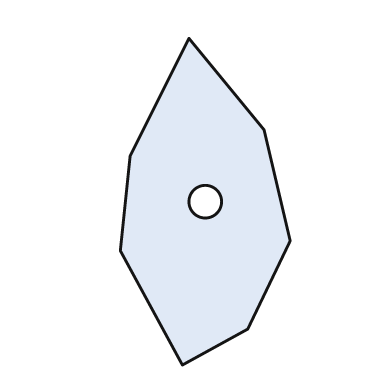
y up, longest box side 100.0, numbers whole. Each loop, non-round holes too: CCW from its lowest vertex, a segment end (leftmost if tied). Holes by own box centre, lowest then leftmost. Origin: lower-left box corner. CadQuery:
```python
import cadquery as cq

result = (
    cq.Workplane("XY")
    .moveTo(19.0, 0.0)
    .lineTo(39.0, 11.0)
    .lineTo(52.0, 38.0)
    .lineTo(44.0, 72.0)
    .lineTo(21.0, 100.0)
    .lineTo(3.0, 64.0)
    .lineTo(0.0, 35.0)
    .close()
    .moveTo(26.0, 50.0)
    .circle(5.0)
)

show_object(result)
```